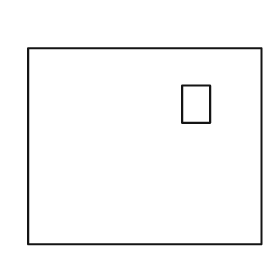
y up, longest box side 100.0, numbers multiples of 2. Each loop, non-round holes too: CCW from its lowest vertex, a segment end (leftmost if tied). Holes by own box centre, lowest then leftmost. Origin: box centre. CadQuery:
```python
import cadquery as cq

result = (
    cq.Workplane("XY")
    .moveTo(-50.0, -42.0)
    .lineTo(50.0, -42.0)
    .lineTo(50.0, 42.0)
    .lineTo(-50.0, 42.0)
    .close()
    .moveTo(16.0, 10.0)
    .lineTo(28.0, 10.0)
    .lineTo(28.0, 26.0)
    .lineTo(16.0, 26.0)
    .close()
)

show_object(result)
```